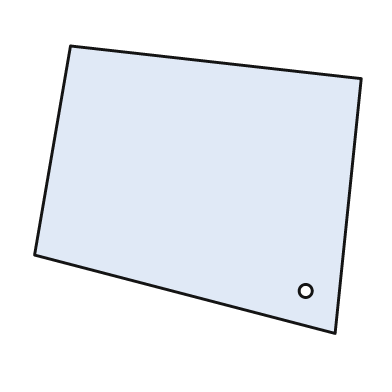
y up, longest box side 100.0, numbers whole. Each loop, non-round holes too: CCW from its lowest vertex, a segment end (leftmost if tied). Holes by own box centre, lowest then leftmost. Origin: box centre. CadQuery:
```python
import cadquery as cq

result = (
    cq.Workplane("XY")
    .moveTo(42.0, -44.0)
    .lineTo(50.0, 34.0)
    .lineTo(-39.0, 44.0)
    .lineTo(-50.0, -20.0)
    .close()
    .moveTo(33.0, -31.0)
    .circle(2.0)
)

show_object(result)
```